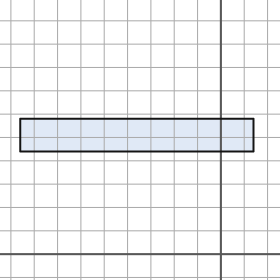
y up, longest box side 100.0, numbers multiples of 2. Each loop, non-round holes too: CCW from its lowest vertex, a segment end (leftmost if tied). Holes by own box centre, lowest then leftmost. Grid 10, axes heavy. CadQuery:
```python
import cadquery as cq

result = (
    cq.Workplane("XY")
    .moveTo(-86.0, 44.0)
    .lineTo(14.0, 44.0)
    .lineTo(14.0, 58.0)
    .lineTo(-86.0, 58.0)
    .close()
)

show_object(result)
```